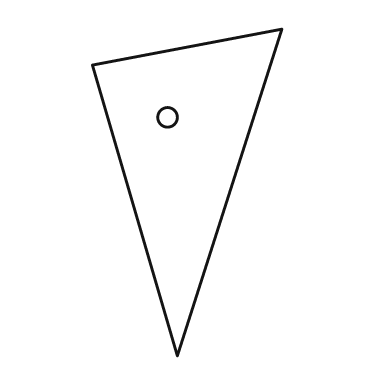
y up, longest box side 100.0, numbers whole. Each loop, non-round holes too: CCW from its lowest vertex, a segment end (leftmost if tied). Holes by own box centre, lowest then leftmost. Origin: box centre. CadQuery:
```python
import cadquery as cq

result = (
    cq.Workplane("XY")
    .moveTo(-3.0, -50.0)
    .lineTo(29.0, 50.0)
    .lineTo(-29.0, 39.0)
    .close()
    .moveTo(-6.0, 23.0)
    .circle(3.0)
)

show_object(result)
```